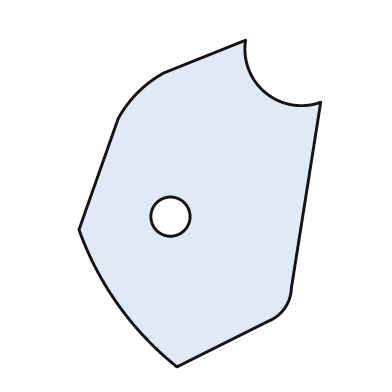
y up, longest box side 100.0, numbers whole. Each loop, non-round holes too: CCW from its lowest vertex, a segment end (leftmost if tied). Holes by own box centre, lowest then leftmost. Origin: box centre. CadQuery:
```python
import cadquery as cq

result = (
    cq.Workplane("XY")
    .moveTo(-7.0, -50.0)
    .lineTo(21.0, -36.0)
    .threePointArc((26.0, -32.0), (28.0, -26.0))
    .lineTo(37.0, 31.0)
    .threePointArc((20.0, 34.0), (14.0, 50.0))
    .lineTo(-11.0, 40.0)
    .threePointArc((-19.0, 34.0), (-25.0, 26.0))
    .lineTo(-37.0, -8.0)
    .threePointArc((-25.0, -31.0), (-7.0, -50.0))
    .close()
    .moveTo(-9.0, -4.0)
    .circle(6.0)
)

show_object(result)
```